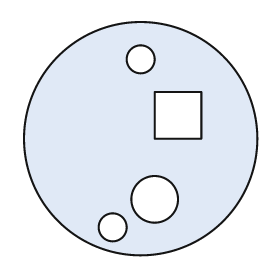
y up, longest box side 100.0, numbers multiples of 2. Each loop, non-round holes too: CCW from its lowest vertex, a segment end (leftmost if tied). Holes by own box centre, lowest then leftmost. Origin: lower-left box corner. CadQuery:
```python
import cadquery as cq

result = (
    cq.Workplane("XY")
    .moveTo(50.0, 50.0)
    .circle(50.0)
    .moveTo(38.0, 12.0)
    .circle(6.0)
    .moveTo(56.0, 24.0)
    .circle(10.0)
    .moveTo(56.0, 50.0)
    .lineTo(76.0, 50.0)
    .lineTo(76.0, 70.0)
    .lineTo(56.0, 70.0)
    .close()
    .moveTo(50.0, 84.0)
    .circle(6.0)
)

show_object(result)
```